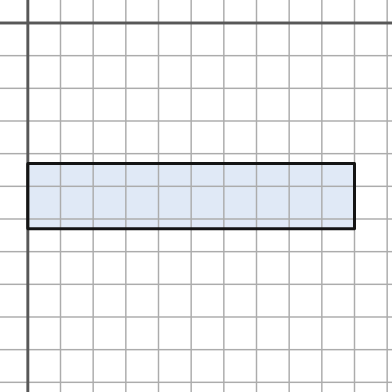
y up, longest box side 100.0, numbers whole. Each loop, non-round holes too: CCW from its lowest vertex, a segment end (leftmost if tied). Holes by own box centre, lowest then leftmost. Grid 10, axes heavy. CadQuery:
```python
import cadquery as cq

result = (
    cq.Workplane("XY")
    .moveTo(0.0, -63.0)
    .lineTo(100.0, -63.0)
    .lineTo(100.0, -43.0)
    .lineTo(0.0, -43.0)
    .close()
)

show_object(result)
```